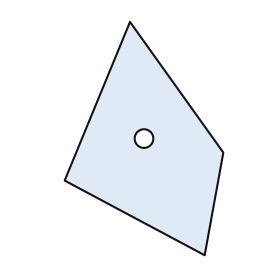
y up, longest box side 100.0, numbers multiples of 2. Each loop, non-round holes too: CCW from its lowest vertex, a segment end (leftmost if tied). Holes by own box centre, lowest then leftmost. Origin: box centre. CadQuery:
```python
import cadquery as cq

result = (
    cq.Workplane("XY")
    .moveTo(26.0, -50.0)
    .lineTo(34.0, -6.0)
    .lineTo(-6.0, 50.0)
    .lineTo(-34.0, -18.0)
    .close()
    .moveTo(0.0, 0.0)
    .circle(4.0)
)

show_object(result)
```